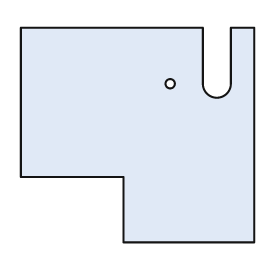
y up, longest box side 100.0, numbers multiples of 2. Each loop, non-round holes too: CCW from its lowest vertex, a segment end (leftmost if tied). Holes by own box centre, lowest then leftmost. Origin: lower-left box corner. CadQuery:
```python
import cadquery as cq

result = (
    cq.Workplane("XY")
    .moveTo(44.0, 0.0)
    .lineTo(100.0, 0.0)
    .lineTo(100.0, 92.0)
    .lineTo(90.0, 92.0)
    .lineTo(90.0, 68.0)
    .threePointArc((84.0, 62.0), (78.0, 68.0))
    .lineTo(78.0, 92.0)
    .lineTo(0.0, 92.0)
    .lineTo(0.0, 28.0)
    .lineTo(44.0, 28.0)
    .close()
    .moveTo(64.0, 68.0)
    .circle(2.0)
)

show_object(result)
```